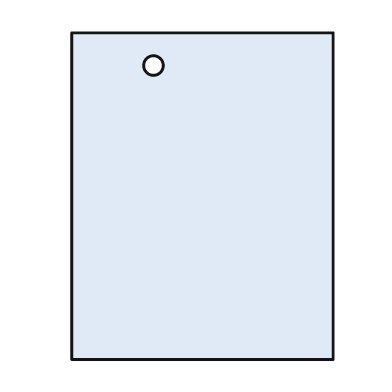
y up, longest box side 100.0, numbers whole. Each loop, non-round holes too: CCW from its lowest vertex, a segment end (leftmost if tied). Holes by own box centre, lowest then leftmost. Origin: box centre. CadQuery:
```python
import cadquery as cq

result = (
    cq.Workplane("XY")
    .moveTo(-40.0, -50.0)
    .lineTo(40.0, -50.0)
    .lineTo(40.0, 50.0)
    .lineTo(-40.0, 50.0)
    .close()
    .moveTo(-15.0, 40.0)
    .circle(3.0)
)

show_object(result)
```